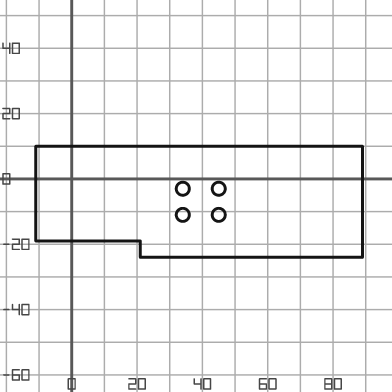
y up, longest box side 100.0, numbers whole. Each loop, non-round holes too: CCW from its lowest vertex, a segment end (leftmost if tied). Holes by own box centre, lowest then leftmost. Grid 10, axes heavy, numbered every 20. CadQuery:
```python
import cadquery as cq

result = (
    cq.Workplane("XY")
    .moveTo(21.0, -24.0)
    .lineTo(89.0, -24.0)
    .lineTo(89.0, 10.0)
    .lineTo(-11.0, 10.0)
    .lineTo(-11.0, -19.0)
    .lineTo(21.0, -19.0)
    .close()
    .moveTo(34.0, -11.0)
    .circle(2.0)
    .moveTo(45.0, -11.0)
    .circle(2.0)
    .moveTo(34.0, -3.0)
    .circle(2.0)
    .moveTo(45.0, -3.0)
    .circle(2.0)
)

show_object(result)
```